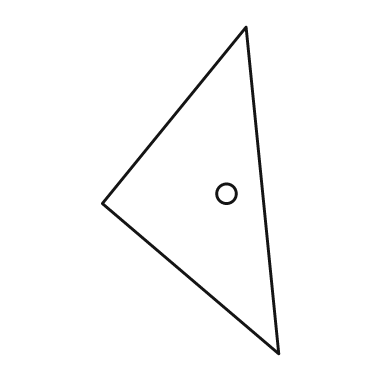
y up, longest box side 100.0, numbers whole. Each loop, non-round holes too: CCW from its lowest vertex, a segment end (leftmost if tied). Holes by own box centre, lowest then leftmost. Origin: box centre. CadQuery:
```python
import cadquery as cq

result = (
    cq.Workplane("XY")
    .moveTo(27.0, -50.0)
    .lineTo(17.0, 50.0)
    .lineTo(-27.0, -4.0)
    .close()
    .moveTo(11.0, -1.0)
    .circle(3.0)
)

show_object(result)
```